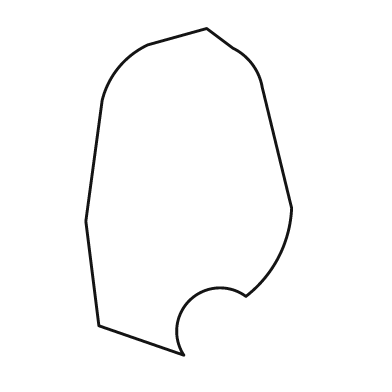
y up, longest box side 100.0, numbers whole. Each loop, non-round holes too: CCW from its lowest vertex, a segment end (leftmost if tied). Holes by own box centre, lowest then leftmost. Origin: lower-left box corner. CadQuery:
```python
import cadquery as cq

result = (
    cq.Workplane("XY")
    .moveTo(30.0, 0.0)
    .threePointArc((32.0, 17.0), (49.0, 18.0))
    .threePointArc((59.0, 30.0), (63.0, 45.0))
    .lineTo(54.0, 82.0)
    .threePointArc((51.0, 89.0), (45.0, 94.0))
    .lineTo(37.0, 100.0)
    .lineTo(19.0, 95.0)
    .threePointArc((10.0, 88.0), (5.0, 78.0))
    .lineTo(0.0, 41.0)
    .lineTo(4.0, 9.0)
    .close()
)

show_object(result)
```